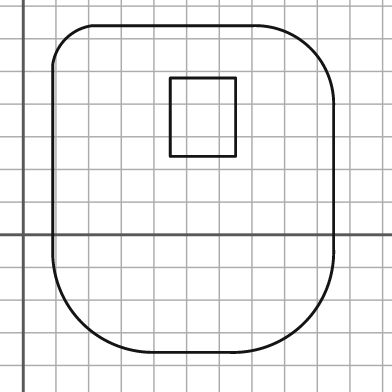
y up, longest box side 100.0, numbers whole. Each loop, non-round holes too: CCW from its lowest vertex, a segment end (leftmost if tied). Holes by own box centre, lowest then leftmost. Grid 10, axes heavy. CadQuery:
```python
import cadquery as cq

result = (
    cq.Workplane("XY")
    .moveTo(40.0, -36.0)
    .lineTo(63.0, -36.0)
    .threePointArc((86.0, -27.0), (95.0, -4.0))
    .lineTo(95.0, 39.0)
    .threePointArc((88.0, 57.0), (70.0, 64.0))
    .lineTo(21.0, 64.0)
    .threePointArc((13.0, 60.0), (9.0, 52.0))
    .lineTo(9.0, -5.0)
    .threePointArc((18.0, -27.0), (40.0, -36.0))
    .close()
    .moveTo(45.0, 24.0)
    .lineTo(65.0, 24.0)
    .lineTo(65.0, 48.0)
    .lineTo(45.0, 48.0)
    .close()
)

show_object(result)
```